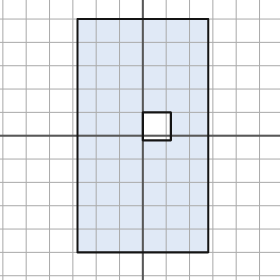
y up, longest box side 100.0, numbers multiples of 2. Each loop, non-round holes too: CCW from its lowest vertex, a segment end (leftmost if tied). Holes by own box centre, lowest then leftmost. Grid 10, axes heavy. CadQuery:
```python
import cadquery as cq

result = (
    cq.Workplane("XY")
    .moveTo(-28.0, -50.0)
    .lineTo(28.0, -50.0)
    .lineTo(28.0, 50.0)
    .lineTo(-28.0, 50.0)
    .close()
    .moveTo(0.0, -2.0)
    .lineTo(12.0, -2.0)
    .lineTo(12.0, 10.0)
    .lineTo(0.0, 10.0)
    .close()
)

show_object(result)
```